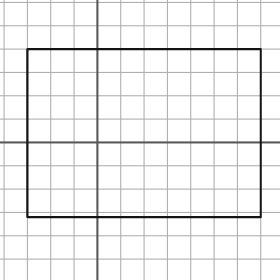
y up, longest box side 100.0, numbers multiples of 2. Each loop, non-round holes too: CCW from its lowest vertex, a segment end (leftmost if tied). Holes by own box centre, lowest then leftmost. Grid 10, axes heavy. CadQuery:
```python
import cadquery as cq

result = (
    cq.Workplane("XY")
    .moveTo(-30.0, -32.0)
    .lineTo(70.0, -32.0)
    .lineTo(70.0, 40.0)
    .lineTo(-30.0, 40.0)
    .close()
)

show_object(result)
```